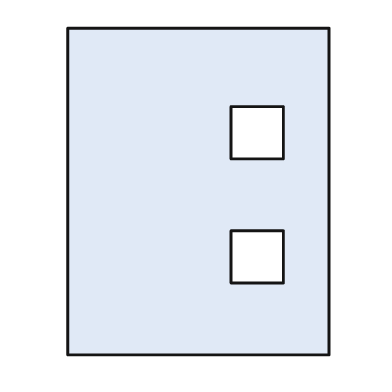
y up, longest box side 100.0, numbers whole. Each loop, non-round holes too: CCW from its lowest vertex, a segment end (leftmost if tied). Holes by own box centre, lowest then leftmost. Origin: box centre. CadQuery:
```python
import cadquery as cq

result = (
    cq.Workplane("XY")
    .moveTo(-40.0, -50.0)
    .lineTo(40.0, -50.0)
    .lineTo(40.0, 50.0)
    .lineTo(-40.0, 50.0)
    .close()
    .moveTo(10.0, -28.0)
    .lineTo(26.0, -28.0)
    .lineTo(26.0, -12.0)
    .lineTo(10.0, -12.0)
    .close()
    .moveTo(10.0, 10.0)
    .lineTo(26.0, 10.0)
    .lineTo(26.0, 26.0)
    .lineTo(10.0, 26.0)
    .close()
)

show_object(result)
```